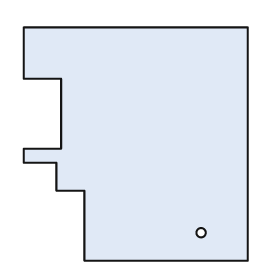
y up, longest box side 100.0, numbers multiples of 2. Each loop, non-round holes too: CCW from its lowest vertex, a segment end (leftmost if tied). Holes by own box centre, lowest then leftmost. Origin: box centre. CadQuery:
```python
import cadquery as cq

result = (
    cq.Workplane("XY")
    .moveTo(-22.0, -50.0)
    .lineTo(48.0, -50.0)
    .lineTo(48.0, 50.0)
    .lineTo(-48.0, 50.0)
    .lineTo(-48.0, 28.0)
    .lineTo(-32.0, 28.0)
    .lineTo(-32.0, -2.0)
    .lineTo(-48.0, -2.0)
    .lineTo(-48.0, -8.0)
    .lineTo(-34.0, -8.0)
    .lineTo(-34.0, -20.0)
    .lineTo(-22.0, -20.0)
    .close()
    .moveTo(28.0, -38.0)
    .circle(2.0)
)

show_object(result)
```